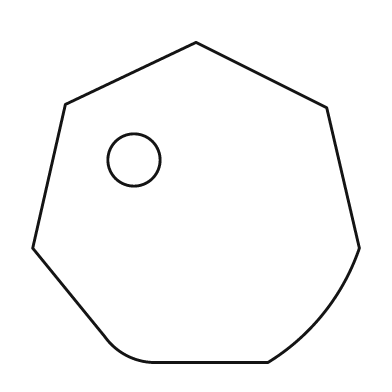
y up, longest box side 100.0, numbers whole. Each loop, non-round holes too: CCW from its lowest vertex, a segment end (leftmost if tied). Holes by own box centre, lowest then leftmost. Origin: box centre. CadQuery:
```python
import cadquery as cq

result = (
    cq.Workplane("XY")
    .moveTo(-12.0, -49.0)
    .lineTo(22.0, -49.0)
    .threePointArc((39.0, -34.0), (50.0, -14.0))
    .lineTo(40.0, 29.0)
    .lineTo(0.0, 49.0)
    .lineTo(-40.0, 30.0)
    .lineTo(-50.0, -14.0)
    .lineTo(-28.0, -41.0)
    .threePointArc((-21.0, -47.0), (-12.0, -49.0))
    .close()
    .moveTo(-19.0, 13.0)
    .circle(8.0)
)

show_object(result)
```